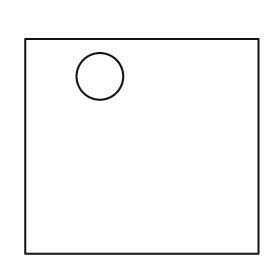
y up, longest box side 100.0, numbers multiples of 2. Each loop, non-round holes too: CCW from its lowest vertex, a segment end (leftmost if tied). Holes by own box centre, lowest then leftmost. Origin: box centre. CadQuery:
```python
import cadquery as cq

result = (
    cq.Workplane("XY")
    .moveTo(-50.0, -46.0)
    .lineTo(50.0, -46.0)
    .lineTo(50.0, 46.0)
    .lineTo(-50.0, 46.0)
    .close()
    .moveTo(-18.0, 30.0)
    .circle(10.0)
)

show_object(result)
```